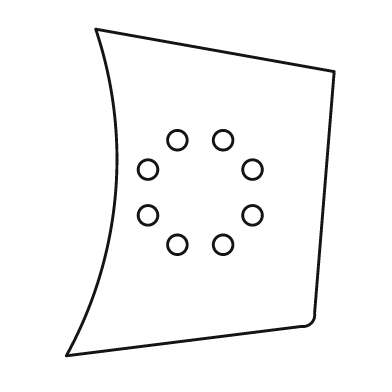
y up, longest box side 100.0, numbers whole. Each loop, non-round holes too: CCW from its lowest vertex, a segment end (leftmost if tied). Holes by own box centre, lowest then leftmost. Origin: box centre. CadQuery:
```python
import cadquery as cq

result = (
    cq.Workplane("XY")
    .moveTo(-41.0, -50.0)
    .lineTo(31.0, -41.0)
    .threePointArc((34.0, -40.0), (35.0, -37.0))
    .lineTo(41.0, 37.0)
    .lineTo(-32.0, 50.0)
    .threePointArc((-26.0, -1.0), (-41.0, -50.0))
    .close()
    .moveTo(-7.0, -16.0)
    .circle(3.0)
    .moveTo(7.0, -16.0)
    .circle(3.0)
    .moveTo(-16.0, -7.0)
    .circle(3.0)
    .moveTo(16.0, -7.0)
    .circle(3.0)
    .moveTo(-16.0, 7.0)
    .circle(3.0)
    .moveTo(16.0, 7.0)
    .circle(3.0)
    .moveTo(-7.0, 16.0)
    .circle(3.0)
    .moveTo(7.0, 16.0)
    .circle(3.0)
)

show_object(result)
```